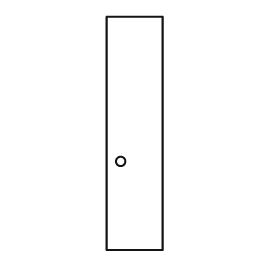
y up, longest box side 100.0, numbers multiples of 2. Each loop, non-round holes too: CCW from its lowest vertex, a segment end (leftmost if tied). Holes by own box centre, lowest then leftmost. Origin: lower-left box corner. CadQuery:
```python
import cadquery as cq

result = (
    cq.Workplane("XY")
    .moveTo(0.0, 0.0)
    .lineTo(24.0, 0.0)
    .lineTo(24.0, 100.0)
    .lineTo(0.0, 100.0)
    .close()
    .moveTo(6.0, 38.0)
    .circle(2.0)
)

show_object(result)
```